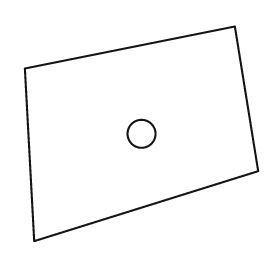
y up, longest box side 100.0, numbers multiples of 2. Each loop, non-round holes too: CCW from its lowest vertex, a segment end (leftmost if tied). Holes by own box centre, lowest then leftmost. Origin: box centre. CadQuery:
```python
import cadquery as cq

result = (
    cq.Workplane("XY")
    .moveTo(-46.0, -46.0)
    .lineTo(50.0, -16.0)
    .lineTo(40.0, 46.0)
    .lineTo(-50.0, 28.0)
    .close()
    .moveTo(0.0, 0.0)
    .circle(6.0)
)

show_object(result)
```